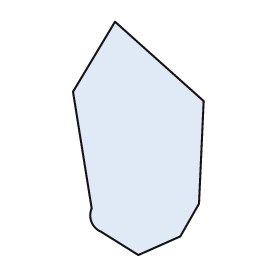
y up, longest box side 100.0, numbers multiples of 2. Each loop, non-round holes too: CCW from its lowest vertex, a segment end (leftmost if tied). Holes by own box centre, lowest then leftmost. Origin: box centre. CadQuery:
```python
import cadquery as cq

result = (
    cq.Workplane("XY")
    .moveTo(0.0, -50.0)
    .lineTo(18.0, -42.0)
    .lineTo(26.0, -28.0)
    .lineTo(28.0, 16.0)
    .lineTo(-10.0, 50.0)
    .lineTo(-28.0, 20.0)
    .lineTo(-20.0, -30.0)
    .threePointArc((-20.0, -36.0), (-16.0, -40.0))
    .close()
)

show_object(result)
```